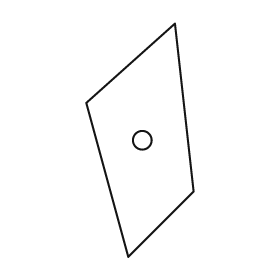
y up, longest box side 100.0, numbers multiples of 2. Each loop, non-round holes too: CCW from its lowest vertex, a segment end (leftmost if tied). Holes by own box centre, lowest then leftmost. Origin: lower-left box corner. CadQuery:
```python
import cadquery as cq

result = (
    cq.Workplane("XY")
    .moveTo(18.0, 0.0)
    .lineTo(46.0, 28.0)
    .lineTo(38.0, 100.0)
    .lineTo(0.0, 66.0)
    .close()
    .moveTo(24.0, 50.0)
    .circle(4.0)
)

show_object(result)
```